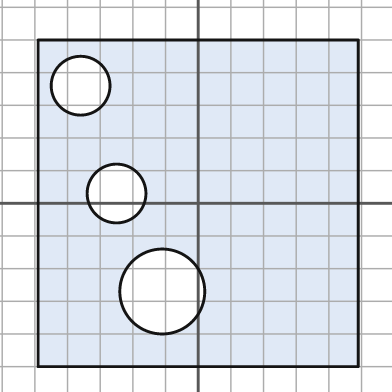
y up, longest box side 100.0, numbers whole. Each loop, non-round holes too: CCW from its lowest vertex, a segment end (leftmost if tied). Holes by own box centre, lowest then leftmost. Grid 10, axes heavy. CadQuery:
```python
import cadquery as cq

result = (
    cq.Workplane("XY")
    .moveTo(-49.0, -50.0)
    .lineTo(49.0, -50.0)
    .lineTo(49.0, 50.0)
    .lineTo(-49.0, 50.0)
    .close()
    .moveTo(-11.0, -27.0)
    .circle(13.0)
    .moveTo(-25.0, 3.0)
    .circle(9.0)
    .moveTo(-36.0, 36.0)
    .circle(9.0)
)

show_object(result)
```